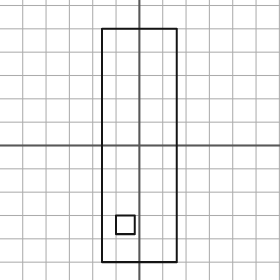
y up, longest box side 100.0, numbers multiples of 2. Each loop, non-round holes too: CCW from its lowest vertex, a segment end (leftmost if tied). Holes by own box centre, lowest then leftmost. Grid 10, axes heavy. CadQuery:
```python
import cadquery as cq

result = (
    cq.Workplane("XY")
    .moveTo(-16.0, -50.0)
    .lineTo(16.0, -50.0)
    .lineTo(16.0, 50.0)
    .lineTo(-16.0, 50.0)
    .close()
    .moveTo(-10.0, -38.0)
    .lineTo(-2.0, -38.0)
    .lineTo(-2.0, -30.0)
    .lineTo(-10.0, -30.0)
    .close()
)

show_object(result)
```